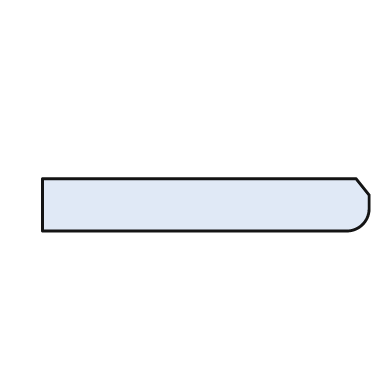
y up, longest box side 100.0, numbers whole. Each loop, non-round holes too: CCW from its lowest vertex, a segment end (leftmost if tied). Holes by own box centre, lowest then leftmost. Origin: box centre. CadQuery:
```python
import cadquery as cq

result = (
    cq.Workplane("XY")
    .moveTo(-50.0, -8.0)
    .lineTo(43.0, -8.0)
    .threePointArc((48.0, -6.0), (50.0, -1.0))
    .lineTo(50.0, 3.0)
    .lineTo(46.0, 8.0)
    .lineTo(-50.0, 8.0)
    .close()
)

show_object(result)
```